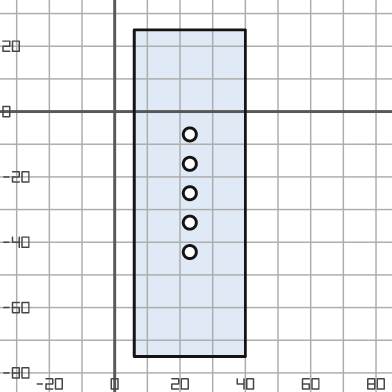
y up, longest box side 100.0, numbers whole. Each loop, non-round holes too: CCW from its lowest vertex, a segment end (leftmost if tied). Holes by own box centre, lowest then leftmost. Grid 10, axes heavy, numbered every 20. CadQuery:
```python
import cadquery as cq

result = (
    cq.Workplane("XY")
    .moveTo(6.0, -75.0)
    .lineTo(40.0, -75.0)
    .lineTo(40.0, 25.0)
    .lineTo(6.0, 25.0)
    .close()
    .moveTo(23.0, -43.0)
    .circle(2.0)
    .moveTo(23.0, -34.0)
    .circle(2.0)
    .moveTo(23.0, -25.0)
    .circle(2.0)
    .moveTo(23.0, -16.0)
    .circle(2.0)
    .moveTo(23.0, -7.0)
    .circle(2.0)
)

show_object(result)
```